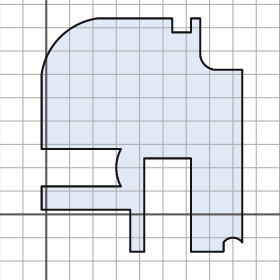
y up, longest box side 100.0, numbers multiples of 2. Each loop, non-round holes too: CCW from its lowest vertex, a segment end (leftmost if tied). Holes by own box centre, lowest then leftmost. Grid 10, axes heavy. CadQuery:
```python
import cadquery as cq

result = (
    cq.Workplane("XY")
    .moveTo(36.0, -16.0)
    .lineTo(42.0, -16.0)
    .lineTo(42.0, 24.0)
    .lineTo(62.0, 24.0)
    .lineTo(62.0, -16.0)
    .lineTo(76.0, -16.0)
    .lineTo(76.0, -12.0)
    .threePointArc((80.0, -10.0), (84.0, -12.0))
    .lineTo(84.0, 62.0)
    .lineTo(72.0, 62.0)
    .threePointArc((68.0, 64.0), (66.0, 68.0))
    .lineTo(66.0, 84.0)
    .lineTo(62.0, 84.0)
    .lineTo(62.0, 78.0)
    .lineTo(54.0, 78.0)
    .lineTo(54.0, 84.0)
    .lineTo(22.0, 84.0)
    .threePointArc((6.0, 76.0), (-2.0, 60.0))
    .lineTo(-2.0, 28.0)
    .lineTo(32.0, 28.0)
    .threePointArc((30.0, 20.0), (32.0, 12.0))
    .lineTo(-2.0, 12.0)
    .lineTo(-2.0, 2.0)
    .lineTo(36.0, 2.0)
    .close()
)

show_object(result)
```